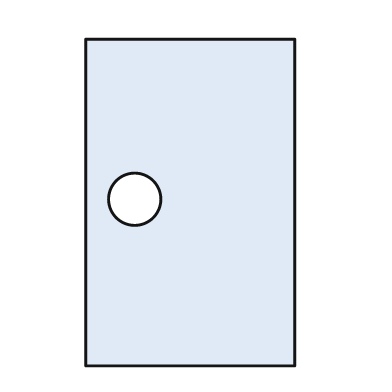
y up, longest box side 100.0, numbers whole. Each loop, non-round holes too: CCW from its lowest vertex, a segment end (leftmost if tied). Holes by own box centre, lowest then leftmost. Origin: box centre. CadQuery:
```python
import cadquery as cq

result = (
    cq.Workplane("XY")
    .moveTo(-32.0, -50.0)
    .lineTo(32.0, -50.0)
    .lineTo(32.0, 50.0)
    .lineTo(-32.0, 50.0)
    .close()
    .moveTo(-17.0, 1.0)
    .circle(8.0)
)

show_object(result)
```